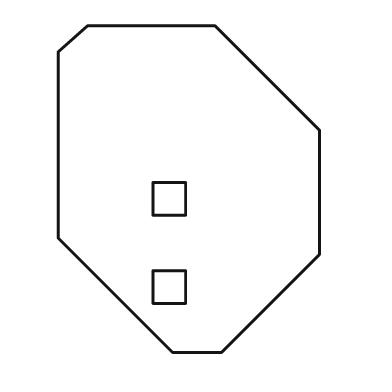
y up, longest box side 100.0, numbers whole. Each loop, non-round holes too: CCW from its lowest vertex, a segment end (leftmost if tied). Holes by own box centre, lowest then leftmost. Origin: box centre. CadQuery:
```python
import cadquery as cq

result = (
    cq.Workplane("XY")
    .moveTo(-5.0, -50.0)
    .lineTo(10.0, -50.0)
    .lineTo(40.0, -20.0)
    .lineTo(40.0, 18.0)
    .lineTo(8.0, 50.0)
    .lineTo(-31.0, 50.0)
    .lineTo(-40.0, 42.0)
    .lineTo(-40.0, -15.0)
    .close()
    .moveTo(-11.0, -35.0)
    .lineTo(-1.0, -35.0)
    .lineTo(-1.0, -25.0)
    .lineTo(-11.0, -25.0)
    .close()
    .moveTo(-11.0, -8.0)
    .lineTo(-1.0, -8.0)
    .lineTo(-1.0, 2.0)
    .lineTo(-11.0, 2.0)
    .close()
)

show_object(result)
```